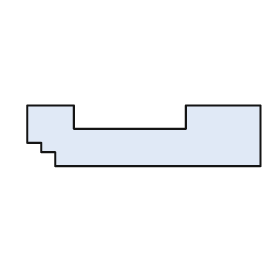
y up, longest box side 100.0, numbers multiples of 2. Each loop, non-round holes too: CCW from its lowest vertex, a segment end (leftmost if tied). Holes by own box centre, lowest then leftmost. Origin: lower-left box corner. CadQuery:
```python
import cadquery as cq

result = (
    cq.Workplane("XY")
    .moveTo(12.0, 0.0)
    .lineTo(100.0, 0.0)
    .lineTo(100.0, 26.0)
    .lineTo(68.0, 26.0)
    .lineTo(68.0, 16.0)
    .lineTo(20.0, 16.0)
    .lineTo(20.0, 26.0)
    .lineTo(0.0, 26.0)
    .lineTo(0.0, 10.0)
    .lineTo(6.0, 10.0)
    .lineTo(6.0, 6.0)
    .lineTo(12.0, 6.0)
    .close()
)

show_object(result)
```